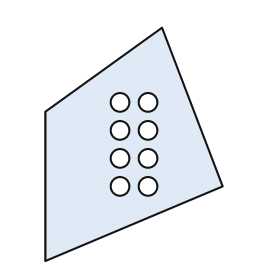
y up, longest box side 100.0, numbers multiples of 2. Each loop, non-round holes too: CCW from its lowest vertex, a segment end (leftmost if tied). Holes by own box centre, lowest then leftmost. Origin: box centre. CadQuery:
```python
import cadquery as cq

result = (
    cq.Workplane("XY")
    .moveTo(-38.0, -50.0)
    .lineTo(38.0, -18.0)
    .lineTo(12.0, 50.0)
    .lineTo(-38.0, 14.0)
    .close()
    .moveTo(-6.0, -18.0)
    .circle(4.0)
    .moveTo(6.0, -18.0)
    .circle(4.0)
    .moveTo(-6.0, -6.0)
    .circle(4.0)
    .moveTo(6.0, -6.0)
    .circle(4.0)
    .moveTo(-6.0, 6.0)
    .circle(4.0)
    .moveTo(6.0, 6.0)
    .circle(4.0)
    .moveTo(-6.0, 18.0)
    .circle(4.0)
    .moveTo(6.0, 18.0)
    .circle(4.0)
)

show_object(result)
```